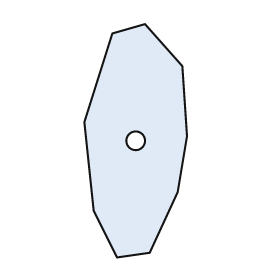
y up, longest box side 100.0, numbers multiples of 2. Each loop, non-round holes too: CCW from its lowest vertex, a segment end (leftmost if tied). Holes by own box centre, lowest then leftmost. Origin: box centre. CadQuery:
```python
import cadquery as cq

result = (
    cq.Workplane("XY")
    .moveTo(-8.0, -50.0)
    .lineTo(6.0, -48.0)
    .lineTo(18.0, -22.0)
    .lineTo(22.0, 2.0)
    .lineTo(20.0, 32.0)
    .lineTo(4.0, 50.0)
    .lineTo(-10.0, 46.0)
    .lineTo(-22.0, 8.0)
    .lineTo(-18.0, -30.0)
    .close()
    .moveTo(0.0, 0.0)
    .circle(4.0)
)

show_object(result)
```